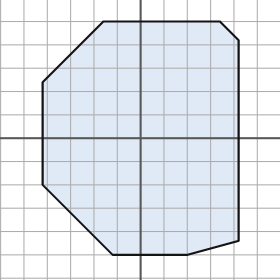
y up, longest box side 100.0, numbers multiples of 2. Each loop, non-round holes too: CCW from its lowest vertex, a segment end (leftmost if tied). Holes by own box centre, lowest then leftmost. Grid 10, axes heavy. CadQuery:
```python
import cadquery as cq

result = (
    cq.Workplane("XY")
    .moveTo(-12.0, -50.0)
    .lineTo(20.0, -50.0)
    .lineTo(42.0, -44.0)
    .lineTo(42.0, 42.0)
    .lineTo(34.0, 50.0)
    .lineTo(-16.0, 50.0)
    .lineTo(-42.0, 24.0)
    .lineTo(-42.0, -20.0)
    .close()
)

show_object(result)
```